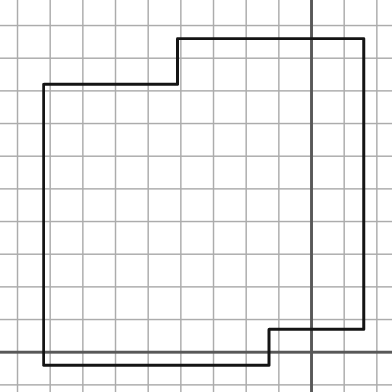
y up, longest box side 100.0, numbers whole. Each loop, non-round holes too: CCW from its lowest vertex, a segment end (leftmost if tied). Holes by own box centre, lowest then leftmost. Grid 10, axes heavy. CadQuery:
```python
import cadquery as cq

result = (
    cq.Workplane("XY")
    .moveTo(-82.0, -4.0)
    .lineTo(-13.0, -4.0)
    .lineTo(-13.0, 7.0)
    .lineTo(16.0, 7.0)
    .lineTo(16.0, 96.0)
    .lineTo(-41.0, 96.0)
    .lineTo(-41.0, 82.0)
    .lineTo(-82.0, 82.0)
    .close()
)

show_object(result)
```